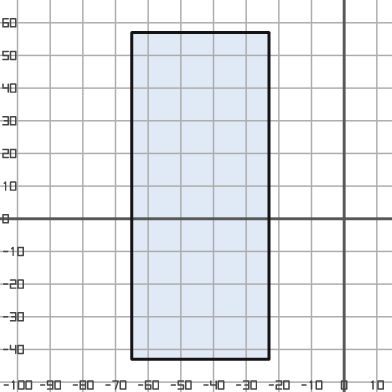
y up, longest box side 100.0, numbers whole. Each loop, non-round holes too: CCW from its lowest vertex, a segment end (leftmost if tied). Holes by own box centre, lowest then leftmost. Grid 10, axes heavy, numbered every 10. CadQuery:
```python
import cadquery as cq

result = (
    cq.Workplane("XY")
    .moveTo(-65.0, -43.0)
    .lineTo(-23.0, -43.0)
    .lineTo(-23.0, 57.0)
    .lineTo(-65.0, 57.0)
    .close()
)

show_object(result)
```